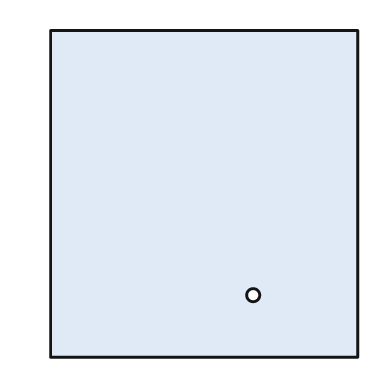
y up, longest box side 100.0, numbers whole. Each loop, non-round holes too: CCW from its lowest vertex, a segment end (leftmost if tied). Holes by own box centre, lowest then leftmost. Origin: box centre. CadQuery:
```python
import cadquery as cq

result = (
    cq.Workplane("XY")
    .moveTo(-47.0, -50.0)
    .lineTo(47.0, -50.0)
    .lineTo(47.0, 50.0)
    .lineTo(-47.0, 50.0)
    .close()
    .moveTo(15.0, -31.0)
    .circle(2.0)
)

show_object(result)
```